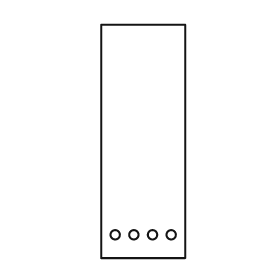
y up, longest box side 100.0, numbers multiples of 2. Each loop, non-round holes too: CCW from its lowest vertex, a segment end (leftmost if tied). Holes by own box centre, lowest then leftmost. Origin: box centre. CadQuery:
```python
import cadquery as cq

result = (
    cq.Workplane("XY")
    .moveTo(-18.0, -50.0)
    .lineTo(18.0, -50.0)
    .lineTo(18.0, 50.0)
    .lineTo(-18.0, 50.0)
    .close()
    .moveTo(-12.0, -40.0)
    .circle(2.0)
    .moveTo(-4.0, -40.0)
    .circle(2.0)
    .moveTo(4.0, -40.0)
    .circle(2.0)
    .moveTo(12.0, -40.0)
    .circle(2.0)
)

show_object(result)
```